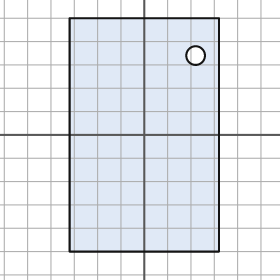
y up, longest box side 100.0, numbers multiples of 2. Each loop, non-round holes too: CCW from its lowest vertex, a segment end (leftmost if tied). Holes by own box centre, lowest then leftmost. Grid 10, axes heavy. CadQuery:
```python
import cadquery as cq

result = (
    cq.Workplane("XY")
    .moveTo(-32.0, -50.0)
    .lineTo(32.0, -50.0)
    .lineTo(32.0, 50.0)
    .lineTo(-32.0, 50.0)
    .close()
    .moveTo(22.0, 34.0)
    .circle(4.0)
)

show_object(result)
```